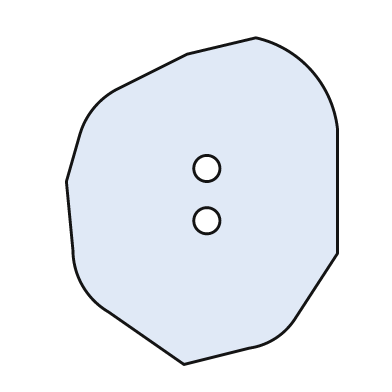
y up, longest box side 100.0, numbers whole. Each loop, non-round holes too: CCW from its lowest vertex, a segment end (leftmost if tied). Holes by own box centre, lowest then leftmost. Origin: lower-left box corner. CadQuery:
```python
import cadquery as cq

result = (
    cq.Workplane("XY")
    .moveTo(36.0, 0.0)
    .lineTo(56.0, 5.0)
    .threePointArc((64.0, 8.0), (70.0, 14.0))
    .lineTo(83.0, 34.0)
    .lineTo(83.0, 72.0)
    .threePointArc((75.0, 90.0), (58.0, 100.0))
    .lineTo(37.0, 95.0)
    .lineTo(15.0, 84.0)
    .threePointArc((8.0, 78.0), (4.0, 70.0))
    .lineTo(0.0, 56.0)
    .lineTo(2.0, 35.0)
    .threePointArc((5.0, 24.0), (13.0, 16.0))
    .close()
    .moveTo(43.0, 44.0)
    .circle(4.0)
    .moveTo(43.0, 60.0)
    .circle(4.0)
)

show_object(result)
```